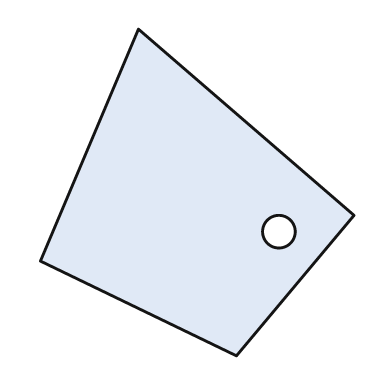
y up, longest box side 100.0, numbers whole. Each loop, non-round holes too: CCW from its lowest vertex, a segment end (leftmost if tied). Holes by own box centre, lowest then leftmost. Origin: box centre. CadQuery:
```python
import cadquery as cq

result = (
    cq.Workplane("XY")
    .moveTo(12.0, -50.0)
    .lineTo(48.0, -7.0)
    .lineTo(-18.0, 50.0)
    .lineTo(-48.0, -21.0)
    .close()
    .moveTo(25.0, -12.0)
    .circle(5.0)
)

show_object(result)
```